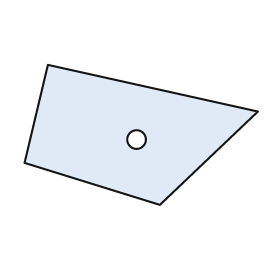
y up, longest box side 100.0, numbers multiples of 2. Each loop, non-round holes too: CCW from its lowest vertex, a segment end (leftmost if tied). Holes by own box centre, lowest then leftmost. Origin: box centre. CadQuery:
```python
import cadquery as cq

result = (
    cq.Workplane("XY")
    .moveTo(8.0, -30.0)
    .lineTo(50.0, 10.0)
    .lineTo(-40.0, 30.0)
    .lineTo(-50.0, -12.0)
    .close()
    .moveTo(-2.0, -2.0)
    .circle(4.0)
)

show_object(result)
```